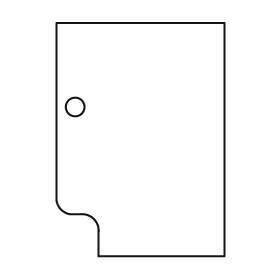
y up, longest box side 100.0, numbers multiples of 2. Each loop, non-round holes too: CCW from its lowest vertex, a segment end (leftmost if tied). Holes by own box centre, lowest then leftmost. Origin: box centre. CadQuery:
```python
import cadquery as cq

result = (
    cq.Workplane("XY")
    .moveTo(-18.0, -50.0)
    .lineTo(36.0, -50.0)
    .lineTo(36.0, 50.0)
    .lineTo(-36.0, 50.0)
    .lineTo(-36.0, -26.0)
    .threePointArc((-34.0, -30.0), (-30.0, -32.0))
    .lineTo(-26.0, -32.0)
    .threePointArc((-20.0, -34.0), (-18.0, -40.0))
    .close()
    .moveTo(-28.0, 14.0)
    .circle(4.0)
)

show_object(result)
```